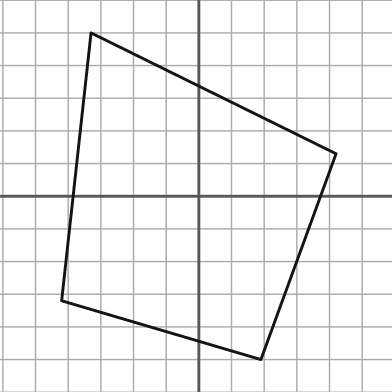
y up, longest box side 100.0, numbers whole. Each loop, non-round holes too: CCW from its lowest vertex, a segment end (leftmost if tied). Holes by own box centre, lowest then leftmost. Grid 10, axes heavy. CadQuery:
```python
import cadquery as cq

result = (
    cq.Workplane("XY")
    .moveTo(19.0, -50.0)
    .lineTo(42.0, 13.0)
    .lineTo(-33.0, 50.0)
    .lineTo(-42.0, -32.0)
    .close()
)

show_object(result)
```